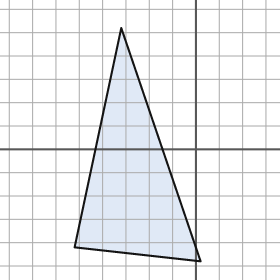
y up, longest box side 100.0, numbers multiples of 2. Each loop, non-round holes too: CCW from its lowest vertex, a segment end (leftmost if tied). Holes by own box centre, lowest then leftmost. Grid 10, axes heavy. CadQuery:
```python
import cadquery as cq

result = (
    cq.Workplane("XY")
    .moveTo(2.0, -48.0)
    .lineTo(-32.0, 52.0)
    .lineTo(-52.0, -42.0)
    .close()
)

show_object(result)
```